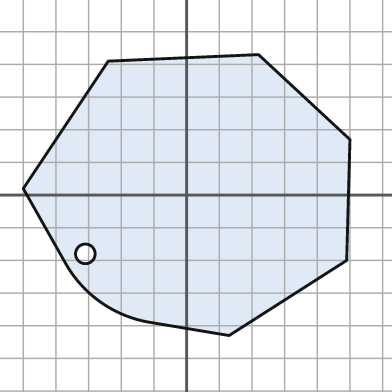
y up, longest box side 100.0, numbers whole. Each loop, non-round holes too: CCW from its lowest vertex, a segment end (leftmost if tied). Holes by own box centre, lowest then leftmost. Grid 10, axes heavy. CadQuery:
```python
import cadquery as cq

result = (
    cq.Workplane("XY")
    .moveTo(13.0, -43.0)
    .lineTo(49.0, -20.0)
    .lineTo(50.0, 17.0)
    .lineTo(22.0, 43.0)
    .lineTo(-24.0, 41.0)
    .lineTo(-50.0, 2.0)
    .lineTo(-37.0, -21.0)
    .threePointArc((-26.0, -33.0), (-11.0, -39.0))
    .close()
    .moveTo(-31.0, -18.0)
    .circle(3.0)
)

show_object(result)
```